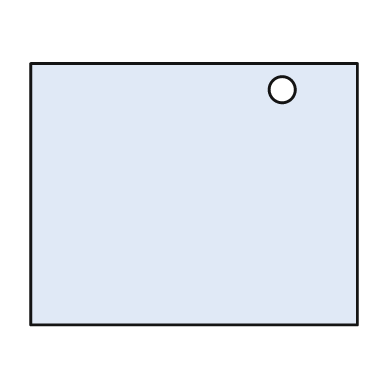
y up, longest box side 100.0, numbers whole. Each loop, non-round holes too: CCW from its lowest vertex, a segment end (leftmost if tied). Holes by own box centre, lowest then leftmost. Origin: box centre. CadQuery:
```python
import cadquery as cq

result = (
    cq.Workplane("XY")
    .moveTo(-50.0, -40.0)
    .lineTo(50.0, -40.0)
    .lineTo(50.0, 40.0)
    .lineTo(-50.0, 40.0)
    .close()
    .moveTo(27.0, 32.0)
    .circle(4.0)
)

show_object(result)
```